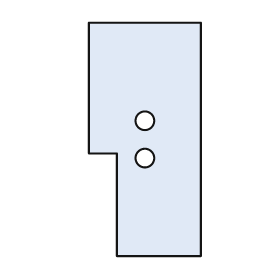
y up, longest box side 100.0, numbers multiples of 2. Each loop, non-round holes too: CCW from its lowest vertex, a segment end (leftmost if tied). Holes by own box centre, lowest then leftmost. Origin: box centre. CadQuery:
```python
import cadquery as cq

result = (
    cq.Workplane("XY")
    .moveTo(-12.0, -50.0)
    .lineTo(24.0, -50.0)
    .lineTo(24.0, 50.0)
    .lineTo(-24.0, 50.0)
    .lineTo(-24.0, -6.0)
    .lineTo(-12.0, -6.0)
    .close()
    .moveTo(0.0, -8.0)
    .circle(4.0)
    .moveTo(0.0, 8.0)
    .circle(4.0)
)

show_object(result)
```